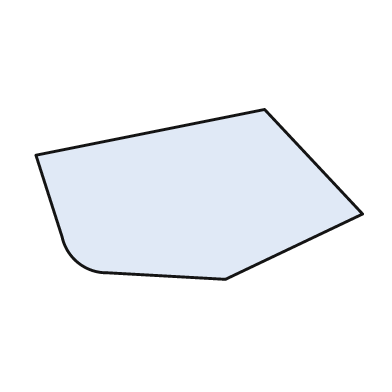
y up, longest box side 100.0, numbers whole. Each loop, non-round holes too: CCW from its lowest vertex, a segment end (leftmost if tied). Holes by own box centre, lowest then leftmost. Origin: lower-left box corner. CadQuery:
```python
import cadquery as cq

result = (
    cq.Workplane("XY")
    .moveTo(58.0, 0.0)
    .lineTo(100.0, 20.0)
    .lineTo(70.0, 52.0)
    .lineTo(0.0, 38.0)
    .lineTo(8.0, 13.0)
    .threePointArc((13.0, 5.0), (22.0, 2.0))
    .close()
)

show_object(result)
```